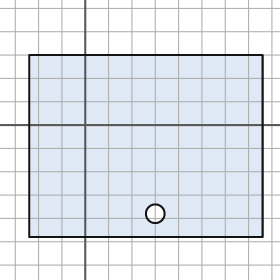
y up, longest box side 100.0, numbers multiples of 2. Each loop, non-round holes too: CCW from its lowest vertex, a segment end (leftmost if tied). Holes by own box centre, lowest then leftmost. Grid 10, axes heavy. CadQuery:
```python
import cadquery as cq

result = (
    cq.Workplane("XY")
    .moveTo(-24.0, -48.0)
    .lineTo(76.0, -48.0)
    .lineTo(76.0, 30.0)
    .lineTo(-24.0, 30.0)
    .close()
    .moveTo(30.0, -38.0)
    .circle(4.0)
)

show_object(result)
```